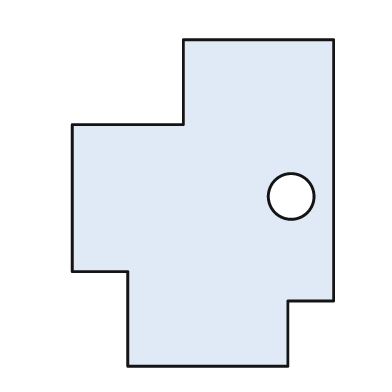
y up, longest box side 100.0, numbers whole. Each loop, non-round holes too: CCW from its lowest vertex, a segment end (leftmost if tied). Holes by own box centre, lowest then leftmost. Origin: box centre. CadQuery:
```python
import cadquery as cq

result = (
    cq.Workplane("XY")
    .moveTo(-23.0, -50.0)
    .lineTo(26.0, -50.0)
    .lineTo(26.0, -30.0)
    .lineTo(40.0, -30.0)
    .lineTo(40.0, 50.0)
    .lineTo(-6.0, 50.0)
    .lineTo(-6.0, 24.0)
    .lineTo(-40.0, 24.0)
    .lineTo(-40.0, -21.0)
    .lineTo(-23.0, -21.0)
    .close()
    .moveTo(27.0, 2.0)
    .circle(7.0)
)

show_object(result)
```